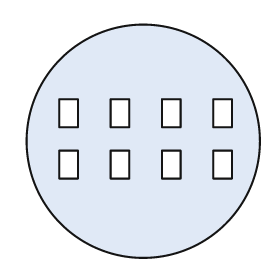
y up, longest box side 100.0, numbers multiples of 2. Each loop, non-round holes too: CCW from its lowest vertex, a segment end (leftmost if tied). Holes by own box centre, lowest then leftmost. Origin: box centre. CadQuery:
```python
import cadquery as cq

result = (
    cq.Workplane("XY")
    .moveTo(0.0, 0.0)
    .circle(50.0)
    .moveTo(-36.0, -16.0)
    .lineTo(-28.0, -16.0)
    .lineTo(-28.0, -4.0)
    .lineTo(-36.0, -4.0)
    .close()
    .moveTo(-14.0, -16.0)
    .lineTo(-6.0, -16.0)
    .lineTo(-6.0, -4.0)
    .lineTo(-14.0, -4.0)
    .close()
    .moveTo(8.0, -16.0)
    .lineTo(16.0, -16.0)
    .lineTo(16.0, -4.0)
    .lineTo(8.0, -4.0)
    .close()
    .moveTo(30.0, -16.0)
    .lineTo(38.0, -16.0)
    .lineTo(38.0, -4.0)
    .lineTo(30.0, -4.0)
    .close()
    .moveTo(-36.0, 6.0)
    .lineTo(-28.0, 6.0)
    .lineTo(-28.0, 18.0)
    .lineTo(-36.0, 18.0)
    .close()
    .moveTo(-14.0, 6.0)
    .lineTo(-6.0, 6.0)
    .lineTo(-6.0, 18.0)
    .lineTo(-14.0, 18.0)
    .close()
    .moveTo(8.0, 6.0)
    .lineTo(16.0, 6.0)
    .lineTo(16.0, 18.0)
    .lineTo(8.0, 18.0)
    .close()
    .moveTo(30.0, 6.0)
    .lineTo(38.0, 6.0)
    .lineTo(38.0, 18.0)
    .lineTo(30.0, 18.0)
    .close()
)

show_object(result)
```